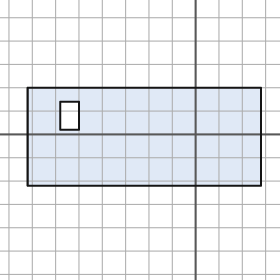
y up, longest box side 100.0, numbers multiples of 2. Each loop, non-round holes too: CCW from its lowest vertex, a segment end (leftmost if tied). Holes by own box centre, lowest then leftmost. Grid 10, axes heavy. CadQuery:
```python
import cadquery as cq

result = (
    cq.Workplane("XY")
    .moveTo(-72.0, -22.0)
    .lineTo(28.0, -22.0)
    .lineTo(28.0, 20.0)
    .lineTo(-72.0, 20.0)
    .close()
    .moveTo(-58.0, 2.0)
    .lineTo(-50.0, 2.0)
    .lineTo(-50.0, 14.0)
    .lineTo(-58.0, 14.0)
    .close()
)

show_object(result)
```